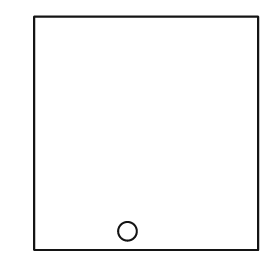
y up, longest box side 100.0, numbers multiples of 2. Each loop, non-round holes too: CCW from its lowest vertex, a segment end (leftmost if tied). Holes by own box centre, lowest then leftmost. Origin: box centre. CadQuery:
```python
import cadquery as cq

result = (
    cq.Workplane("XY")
    .moveTo(-48.0, -50.0)
    .lineTo(48.0, -50.0)
    .lineTo(48.0, 50.0)
    .lineTo(-48.0, 50.0)
    .close()
    .moveTo(-8.0, -42.0)
    .circle(4.0)
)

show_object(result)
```